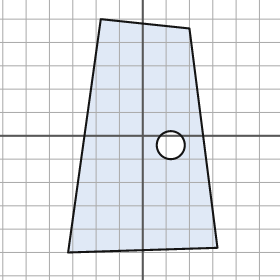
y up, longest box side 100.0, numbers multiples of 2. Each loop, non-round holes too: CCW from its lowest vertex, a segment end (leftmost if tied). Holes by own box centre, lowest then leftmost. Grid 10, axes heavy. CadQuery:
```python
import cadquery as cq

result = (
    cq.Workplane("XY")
    .moveTo(-32.0, -50.0)
    .lineTo(32.0, -48.0)
    .lineTo(20.0, 46.0)
    .lineTo(-18.0, 50.0)
    .close()
    .moveTo(12.0, -4.0)
    .circle(6.0)
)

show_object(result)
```